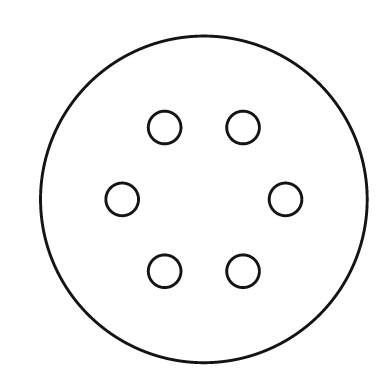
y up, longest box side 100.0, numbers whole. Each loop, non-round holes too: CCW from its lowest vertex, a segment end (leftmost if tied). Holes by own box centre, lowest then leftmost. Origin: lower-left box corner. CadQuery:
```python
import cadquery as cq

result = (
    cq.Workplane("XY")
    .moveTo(50.0, 50.0)
    .circle(50.0)
    .moveTo(38.0, 28.0)
    .circle(5.0)
    .moveTo(62.0, 28.0)
    .circle(5.0)
    .moveTo(25.0, 50.0)
    .circle(5.0)
    .moveTo(75.0, 50.0)
    .circle(5.0)
    .moveTo(38.0, 72.0)
    .circle(5.0)
    .moveTo(62.0, 72.0)
    .circle(5.0)
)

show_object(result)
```